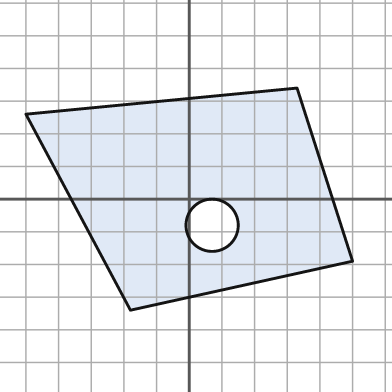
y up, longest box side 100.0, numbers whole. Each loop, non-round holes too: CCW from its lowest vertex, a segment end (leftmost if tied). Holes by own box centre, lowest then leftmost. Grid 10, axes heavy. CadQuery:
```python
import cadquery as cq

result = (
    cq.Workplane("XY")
    .moveTo(-18.0, -34.0)
    .lineTo(50.0, -19.0)
    .lineTo(33.0, 34.0)
    .lineTo(-50.0, 26.0)
    .close()
    .moveTo(7.0, -8.0)
    .circle(8.0)
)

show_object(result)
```